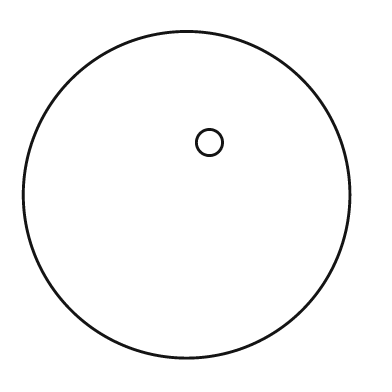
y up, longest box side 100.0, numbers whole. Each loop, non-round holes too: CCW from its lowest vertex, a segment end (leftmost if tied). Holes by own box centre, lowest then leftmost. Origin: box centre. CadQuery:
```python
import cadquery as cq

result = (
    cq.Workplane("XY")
    .moveTo(0.0, 0.0)
    .circle(50.0)
    .moveTo(7.0, 16.0)
    .circle(4.0)
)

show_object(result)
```